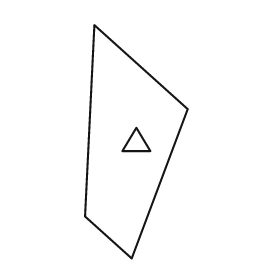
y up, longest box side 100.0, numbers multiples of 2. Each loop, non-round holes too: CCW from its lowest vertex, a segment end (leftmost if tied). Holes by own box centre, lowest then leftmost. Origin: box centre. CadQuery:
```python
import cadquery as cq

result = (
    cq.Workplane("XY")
    .moveTo(-2.0, -50.0)
    .lineTo(22.0, 14.0)
    .lineTo(-18.0, 50.0)
    .lineTo(-22.0, -32.0)
    .close()
    .moveTo(-6.0, -4.0)
    .lineTo(6.0, -4.0)
    .lineTo(0.0, 6.0)
    .close()
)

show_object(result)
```